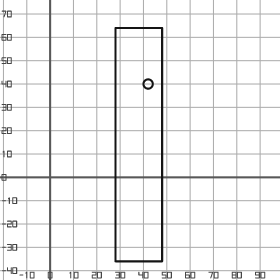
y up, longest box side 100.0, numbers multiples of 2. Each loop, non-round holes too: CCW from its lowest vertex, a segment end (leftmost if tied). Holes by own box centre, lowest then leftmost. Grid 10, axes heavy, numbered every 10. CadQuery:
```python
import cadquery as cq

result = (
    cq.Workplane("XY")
    .moveTo(28.0, -36.0)
    .lineTo(48.0, -36.0)
    .lineTo(48.0, 64.0)
    .lineTo(28.0, 64.0)
    .close()
    .moveTo(42.0, 40.0)
    .circle(2.0)
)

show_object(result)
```